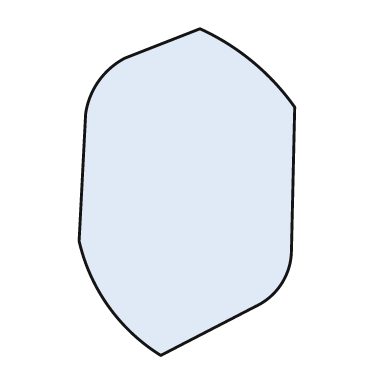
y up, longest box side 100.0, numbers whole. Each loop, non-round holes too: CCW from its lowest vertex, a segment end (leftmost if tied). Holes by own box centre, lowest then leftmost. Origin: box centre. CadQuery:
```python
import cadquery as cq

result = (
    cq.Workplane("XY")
    .moveTo(-8.0, -50.0)
    .lineTo(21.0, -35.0)
    .threePointArc((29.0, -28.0), (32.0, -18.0))
    .lineTo(33.0, 26.0)
    .threePointArc((20.0, 40.0), (4.0, 50.0))
    .lineTo(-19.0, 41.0)
    .threePointArc((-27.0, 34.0), (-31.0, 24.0))
    .lineTo(-33.0, -15.0)
    .threePointArc((-24.0, -35.0), (-8.0, -50.0))
    .close()
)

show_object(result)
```